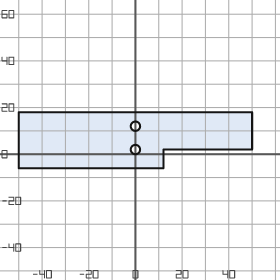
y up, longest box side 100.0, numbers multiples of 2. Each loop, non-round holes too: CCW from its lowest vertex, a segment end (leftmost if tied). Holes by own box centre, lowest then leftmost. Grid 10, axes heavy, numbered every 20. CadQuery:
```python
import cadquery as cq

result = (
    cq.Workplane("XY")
    .moveTo(-50.0, -6.0)
    .lineTo(12.0, -6.0)
    .lineTo(12.0, 2.0)
    .lineTo(50.0, 2.0)
    .lineTo(50.0, 18.0)
    .lineTo(-50.0, 18.0)
    .close()
    .moveTo(0.0, 2.0)
    .circle(2.0)
    .moveTo(0.0, 12.0)
    .circle(2.0)
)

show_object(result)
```